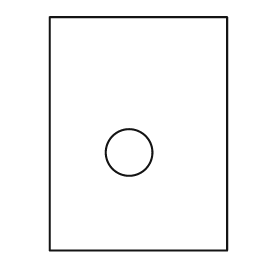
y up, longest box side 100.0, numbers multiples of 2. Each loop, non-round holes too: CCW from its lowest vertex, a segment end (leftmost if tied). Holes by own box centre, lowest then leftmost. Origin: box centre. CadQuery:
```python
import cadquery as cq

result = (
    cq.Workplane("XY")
    .moveTo(-38.0, -50.0)
    .lineTo(38.0, -50.0)
    .lineTo(38.0, 50.0)
    .lineTo(-38.0, 50.0)
    .close()
    .moveTo(-4.0, -8.0)
    .circle(10.0)
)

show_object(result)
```